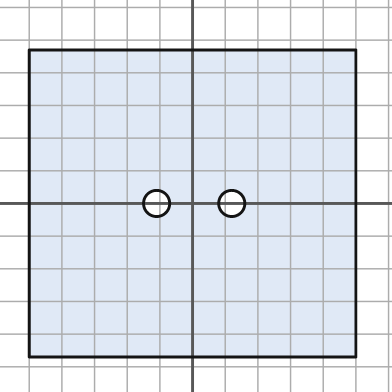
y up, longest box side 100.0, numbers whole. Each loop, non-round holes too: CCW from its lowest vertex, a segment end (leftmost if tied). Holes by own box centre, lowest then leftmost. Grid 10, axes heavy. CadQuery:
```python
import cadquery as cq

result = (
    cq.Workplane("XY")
    .moveTo(-50.0, -47.0)
    .lineTo(50.0, -47.0)
    .lineTo(50.0, 47.0)
    .lineTo(-50.0, 47.0)
    .close()
    .moveTo(-11.0, 0.0)
    .circle(4.0)
    .moveTo(12.0, 0.0)
    .circle(4.0)
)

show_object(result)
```